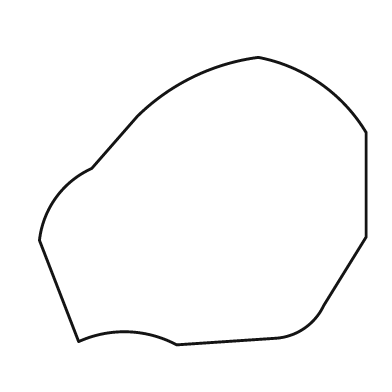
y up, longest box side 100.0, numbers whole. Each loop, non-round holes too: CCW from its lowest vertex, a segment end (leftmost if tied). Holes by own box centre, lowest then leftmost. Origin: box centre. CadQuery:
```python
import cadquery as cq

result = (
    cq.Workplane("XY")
    .moveTo(-8.0, -44.0)
    .lineTo(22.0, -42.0)
    .threePointArc((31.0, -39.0), (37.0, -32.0))
    .lineTo(50.0, -11.0)
    .lineTo(50.0, 21.0)
    .threePointArc((36.0, 36.0), (17.0, 44.0))
    .threePointArc((-3.0, 38.0), (-20.0, 26.0))
    .lineTo(-34.0, 10.0)
    .threePointArc((-45.0, 1.0), (-50.0, -12.0))
    .lineTo(-38.0, -43.0)
    .threePointArc((-23.0, -40.0), (-8.0, -44.0))
    .close()
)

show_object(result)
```